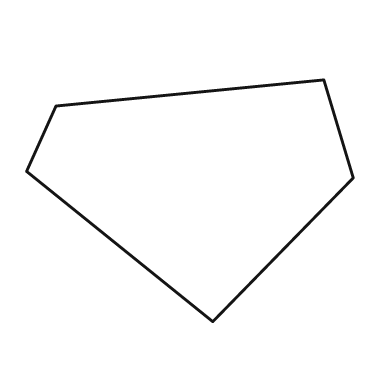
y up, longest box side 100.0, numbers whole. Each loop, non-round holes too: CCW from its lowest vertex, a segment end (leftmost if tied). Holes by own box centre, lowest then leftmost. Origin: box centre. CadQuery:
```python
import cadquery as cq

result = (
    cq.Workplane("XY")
    .moveTo(7.0, -37.0)
    .lineTo(50.0, 7.0)
    .lineTo(41.0, 37.0)
    .lineTo(-41.0, 29.0)
    .lineTo(-50.0, 9.0)
    .close()
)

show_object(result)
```